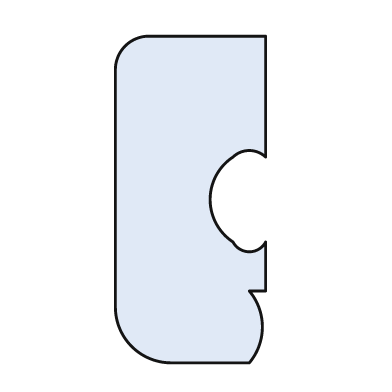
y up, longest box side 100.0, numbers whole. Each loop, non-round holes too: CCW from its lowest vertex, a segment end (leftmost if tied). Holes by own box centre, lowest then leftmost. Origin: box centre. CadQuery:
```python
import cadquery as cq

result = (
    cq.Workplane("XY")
    .moveTo(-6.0, -50.0)
    .lineTo(18.0, -50.0)
    .threePointArc((22.0, -39.0), (18.0, -28.0))
    .lineTo(23.0, -28.0)
    .lineTo(23.0, -13.0)
    .threePointArc((18.0, -16.0), (13.0, -13.0))
    .threePointArc((6.0, 0.0), (13.0, 13.0))
    .threePointArc((18.0, 15.0), (23.0, 13.0))
    .lineTo(23.0, 50.0)
    .lineTo(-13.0, 50.0)
    .threePointArc((-20.0, 47.0), (-23.0, 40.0))
    .lineTo(-23.0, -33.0)
    .threePointArc((-18.0, -45.0), (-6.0, -50.0))
    .close()
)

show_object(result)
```